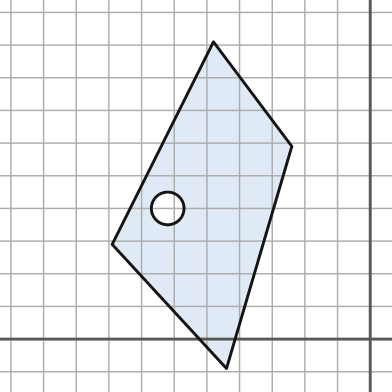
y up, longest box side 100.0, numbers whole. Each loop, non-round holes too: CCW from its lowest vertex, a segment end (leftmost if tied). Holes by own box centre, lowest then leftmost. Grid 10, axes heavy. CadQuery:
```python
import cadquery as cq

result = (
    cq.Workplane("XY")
    .moveTo(-44.0, -9.0)
    .lineTo(-24.0, 59.0)
    .lineTo(-48.0, 91.0)
    .lineTo(-79.0, 29.0)
    .close()
    .moveTo(-62.0, 40.0)
    .circle(5.0)
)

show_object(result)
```